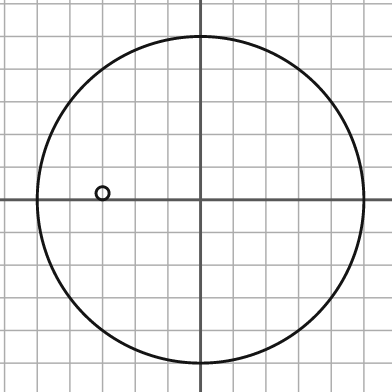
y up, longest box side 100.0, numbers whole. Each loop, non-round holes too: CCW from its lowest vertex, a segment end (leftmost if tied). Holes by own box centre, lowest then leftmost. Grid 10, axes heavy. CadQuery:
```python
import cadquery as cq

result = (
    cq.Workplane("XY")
    .moveTo(0.0, 0.0)
    .circle(50.0)
    .moveTo(-30.0, 2.0)
    .circle(2.0)
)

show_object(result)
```